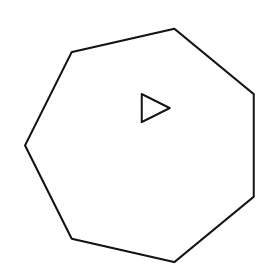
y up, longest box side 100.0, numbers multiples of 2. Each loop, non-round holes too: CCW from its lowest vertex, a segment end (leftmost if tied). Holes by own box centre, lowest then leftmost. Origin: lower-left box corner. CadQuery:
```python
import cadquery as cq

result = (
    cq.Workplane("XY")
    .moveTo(64.0, 0.0)
    .lineTo(98.0, 28.0)
    .lineTo(98.0, 72.0)
    .lineTo(64.0, 100.0)
    .lineTo(20.0, 90.0)
    .lineTo(0.0, 50.0)
    .lineTo(20.0, 10.0)
    .close()
    .moveTo(50.0, 60.0)
    .lineTo(62.0, 66.0)
    .lineTo(50.0, 72.0)
    .close()
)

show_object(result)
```